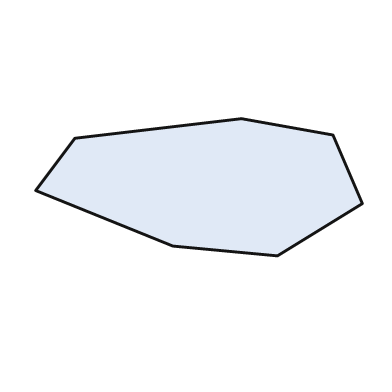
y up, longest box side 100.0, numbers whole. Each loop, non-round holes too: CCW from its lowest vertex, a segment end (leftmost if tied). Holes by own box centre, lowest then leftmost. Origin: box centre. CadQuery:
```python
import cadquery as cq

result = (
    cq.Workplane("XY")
    .moveTo(24.0, -21.0)
    .lineTo(50.0, -5.0)
    .lineTo(41.0, 16.0)
    .lineTo(13.0, 21.0)
    .lineTo(-38.0, 15.0)
    .lineTo(-50.0, -1.0)
    .lineTo(-8.0, -18.0)
    .close()
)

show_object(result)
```